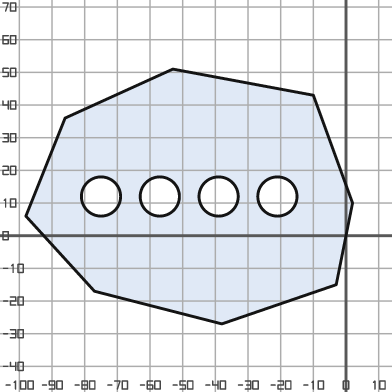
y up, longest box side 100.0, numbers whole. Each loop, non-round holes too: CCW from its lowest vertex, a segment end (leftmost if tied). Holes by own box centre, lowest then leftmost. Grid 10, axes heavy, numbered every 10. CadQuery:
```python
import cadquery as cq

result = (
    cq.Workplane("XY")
    .moveTo(-38.0, -27.0)
    .lineTo(-3.0, -15.0)
    .lineTo(2.0, 10.0)
    .lineTo(-10.0, 43.0)
    .lineTo(-53.0, 51.0)
    .lineTo(-86.0, 36.0)
    .lineTo(-98.0, 6.0)
    .lineTo(-77.0, -17.0)
    .close()
    .moveTo(-75.0, 12.0)
    .circle(6.0)
    .moveTo(-57.0, 12.0)
    .circle(6.0)
    .moveTo(-39.0, 12.0)
    .circle(6.0)
    .moveTo(-21.0, 12.0)
    .circle(6.0)
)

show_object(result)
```